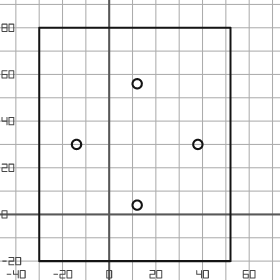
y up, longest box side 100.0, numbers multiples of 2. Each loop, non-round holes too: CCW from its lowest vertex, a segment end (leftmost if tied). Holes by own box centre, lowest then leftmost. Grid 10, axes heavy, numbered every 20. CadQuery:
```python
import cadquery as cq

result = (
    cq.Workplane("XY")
    .moveTo(-30.0, -20.0)
    .lineTo(52.0, -20.0)
    .lineTo(52.0, 80.0)
    .lineTo(-30.0, 80.0)
    .close()
    .moveTo(12.0, 4.0)
    .circle(2.0)
    .moveTo(-14.0, 30.0)
    .circle(2.0)
    .moveTo(38.0, 30.0)
    .circle(2.0)
    .moveTo(12.0, 56.0)
    .circle(2.0)
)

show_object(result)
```